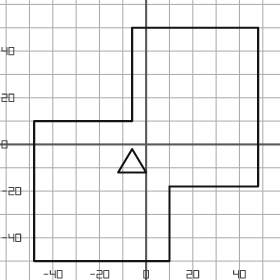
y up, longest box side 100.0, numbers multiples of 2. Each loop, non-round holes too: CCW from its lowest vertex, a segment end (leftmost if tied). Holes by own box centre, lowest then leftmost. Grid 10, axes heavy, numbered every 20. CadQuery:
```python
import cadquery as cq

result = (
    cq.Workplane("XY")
    .moveTo(-48.0, -50.0)
    .lineTo(10.0, -50.0)
    .lineTo(10.0, -18.0)
    .lineTo(48.0, -18.0)
    .lineTo(48.0, 50.0)
    .lineTo(-6.0, 50.0)
    .lineTo(-6.0, 10.0)
    .lineTo(-48.0, 10.0)
    .close()
    .moveTo(-12.0, -12.0)
    .lineTo(0.0, -12.0)
    .lineTo(-6.0, -2.0)
    .close()
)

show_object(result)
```